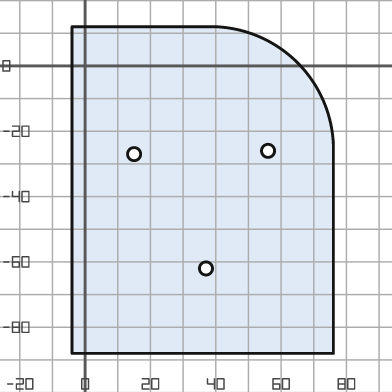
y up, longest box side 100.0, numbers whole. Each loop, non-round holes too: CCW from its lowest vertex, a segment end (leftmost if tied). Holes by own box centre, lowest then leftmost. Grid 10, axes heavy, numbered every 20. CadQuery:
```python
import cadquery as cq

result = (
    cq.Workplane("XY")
    .moveTo(-4.0, -88.0)
    .lineTo(76.0, -88.0)
    .lineTo(76.0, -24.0)
    .threePointArc((65.0, 1.0), (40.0, 12.0))
    .lineTo(-4.0, 12.0)
    .close()
    .moveTo(37.0, -62.0)
    .circle(2.0)
    .moveTo(15.0, -27.0)
    .circle(2.0)
    .moveTo(56.0, -26.0)
    .circle(2.0)
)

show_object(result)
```